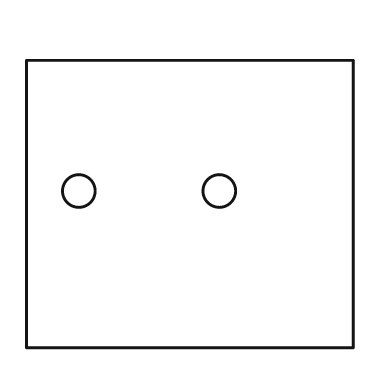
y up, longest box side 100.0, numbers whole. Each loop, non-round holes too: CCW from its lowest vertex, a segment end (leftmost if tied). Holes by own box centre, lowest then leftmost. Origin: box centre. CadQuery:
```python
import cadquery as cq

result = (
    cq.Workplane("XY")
    .moveTo(-50.0, -44.0)
    .lineTo(50.0, -44.0)
    .lineTo(50.0, 44.0)
    .lineTo(-50.0, 44.0)
    .close()
    .moveTo(-34.0, 4.0)
    .circle(5.0)
    .moveTo(9.0, 4.0)
    .circle(5.0)
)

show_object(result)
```